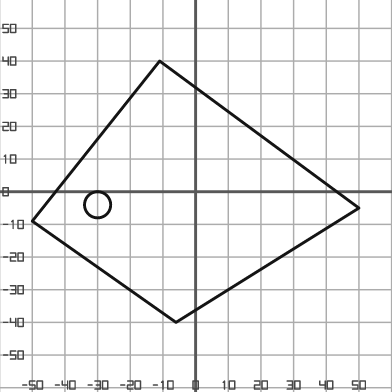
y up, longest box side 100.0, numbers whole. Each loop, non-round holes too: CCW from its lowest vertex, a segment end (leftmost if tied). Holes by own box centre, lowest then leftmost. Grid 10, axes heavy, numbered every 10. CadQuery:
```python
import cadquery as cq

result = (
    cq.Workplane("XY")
    .moveTo(-6.0, -40.0)
    .lineTo(50.0, -5.0)
    .lineTo(-11.0, 40.0)
    .lineTo(-50.0, -9.0)
    .close()
    .moveTo(-30.0, -4.0)
    .circle(4.0)
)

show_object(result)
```